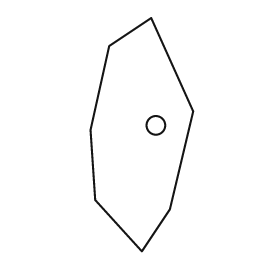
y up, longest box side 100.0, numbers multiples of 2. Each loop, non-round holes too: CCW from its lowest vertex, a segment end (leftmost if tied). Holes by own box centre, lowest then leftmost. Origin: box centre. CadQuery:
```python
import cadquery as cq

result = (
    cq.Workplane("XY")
    .moveTo(0.0, -50.0)
    .lineTo(12.0, -32.0)
    .lineTo(22.0, 10.0)
    .lineTo(4.0, 50.0)
    .lineTo(-14.0, 38.0)
    .lineTo(-22.0, 2.0)
    .lineTo(-20.0, -28.0)
    .close()
    .moveTo(6.0, 4.0)
    .circle(4.0)
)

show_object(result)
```